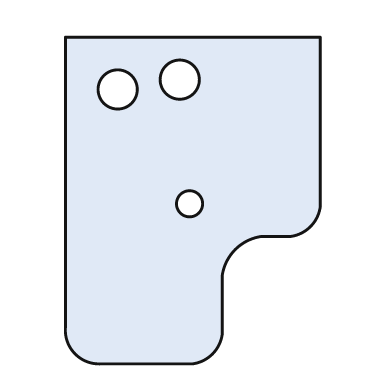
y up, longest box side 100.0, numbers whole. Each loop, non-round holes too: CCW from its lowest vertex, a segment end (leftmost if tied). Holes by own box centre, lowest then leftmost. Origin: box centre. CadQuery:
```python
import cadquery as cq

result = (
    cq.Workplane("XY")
    .moveTo(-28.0, -50.0)
    .lineTo(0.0, -50.0)
    .threePointArc((6.0, -47.0), (9.0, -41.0))
    .lineTo(9.0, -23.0)
    .threePointArc((13.0, -15.0), (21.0, -11.0))
    .lineTo(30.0, -11.0)
    .threePointArc((36.0, -8.0), (39.0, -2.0))
    .lineTo(39.0, 50.0)
    .lineTo(-39.0, 50.0)
    .lineTo(-39.0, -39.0)
    .threePointArc((-36.0, -47.0), (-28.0, -50.0))
    .close()
    .moveTo(-1.0, -1.0)
    .circle(4.0)
    .moveTo(-23.0, 34.0)
    .circle(6.0)
    .moveTo(-4.0, 37.0)
    .circle(6.0)
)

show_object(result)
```